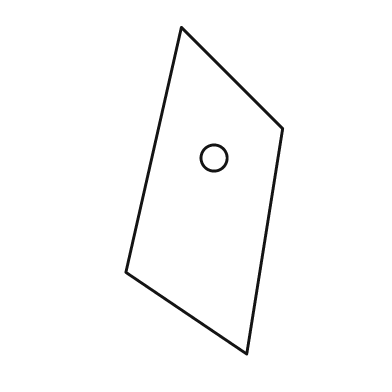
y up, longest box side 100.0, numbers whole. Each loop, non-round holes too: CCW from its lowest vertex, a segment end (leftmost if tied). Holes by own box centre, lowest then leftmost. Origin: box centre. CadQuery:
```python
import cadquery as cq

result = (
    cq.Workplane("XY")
    .moveTo(13.0, -50.0)
    .lineTo(24.0, 19.0)
    .lineTo(-7.0, 50.0)
    .lineTo(-24.0, -25.0)
    .close()
    .moveTo(3.0, 10.0)
    .circle(4.0)
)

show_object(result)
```